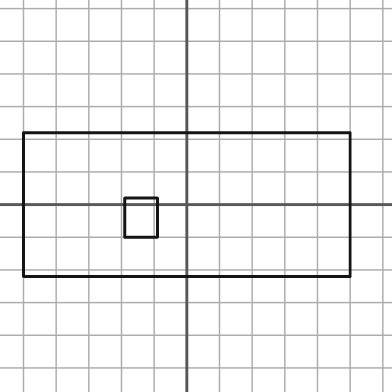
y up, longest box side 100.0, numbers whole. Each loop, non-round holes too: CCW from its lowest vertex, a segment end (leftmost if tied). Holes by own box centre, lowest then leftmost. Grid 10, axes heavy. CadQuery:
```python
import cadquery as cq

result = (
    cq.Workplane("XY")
    .moveTo(-50.0, -22.0)
    .lineTo(50.0, -22.0)
    .lineTo(50.0, 22.0)
    .lineTo(-50.0, 22.0)
    .close()
    .moveTo(-19.0, -10.0)
    .lineTo(-9.0, -10.0)
    .lineTo(-9.0, 2.0)
    .lineTo(-19.0, 2.0)
    .close()
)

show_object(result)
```